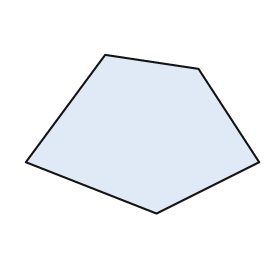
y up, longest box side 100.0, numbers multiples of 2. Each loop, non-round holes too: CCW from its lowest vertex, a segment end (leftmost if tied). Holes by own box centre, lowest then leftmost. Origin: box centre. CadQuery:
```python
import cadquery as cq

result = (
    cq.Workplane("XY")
    .moveTo(6.0, -34.0)
    .lineTo(50.0, -12.0)
    .lineTo(24.0, 28.0)
    .lineTo(-16.0, 34.0)
    .lineTo(-50.0, -12.0)
    .close()
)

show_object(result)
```